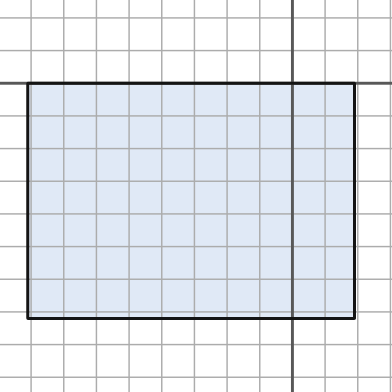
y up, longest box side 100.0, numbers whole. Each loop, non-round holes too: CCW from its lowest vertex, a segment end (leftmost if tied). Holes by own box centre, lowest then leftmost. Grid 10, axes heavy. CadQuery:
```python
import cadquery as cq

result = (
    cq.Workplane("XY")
    .moveTo(-81.0, -72.0)
    .lineTo(19.0, -72.0)
    .lineTo(19.0, 0.0)
    .lineTo(-81.0, 0.0)
    .close()
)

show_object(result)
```